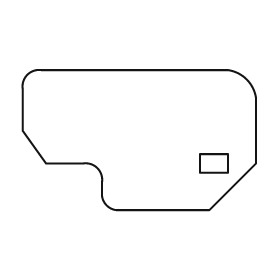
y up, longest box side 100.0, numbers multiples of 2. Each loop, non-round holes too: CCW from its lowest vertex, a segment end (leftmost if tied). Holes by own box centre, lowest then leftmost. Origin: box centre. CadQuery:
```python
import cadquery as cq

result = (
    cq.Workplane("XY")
    .moveTo(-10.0, -30.0)
    .lineTo(30.0, -30.0)
    .lineTo(50.0, -10.0)
    .lineTo(50.0, 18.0)
    .threePointArc((46.0, 26.0), (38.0, 30.0))
    .lineTo(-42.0, 30.0)
    .threePointArc((-48.0, 28.0), (-50.0, 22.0))
    .lineTo(-50.0, 4.0)
    .lineTo(-40.0, -10.0)
    .lineTo(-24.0, -10.0)
    .threePointArc((-18.0, -12.0), (-16.0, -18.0))
    .lineTo(-16.0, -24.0)
    .threePointArc((-14.0, -28.0), (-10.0, -30.0))
    .close()
    .moveTo(26.0, -14.0)
    .lineTo(38.0, -14.0)
    .lineTo(38.0, -6.0)
    .lineTo(26.0, -6.0)
    .close()
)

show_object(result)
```